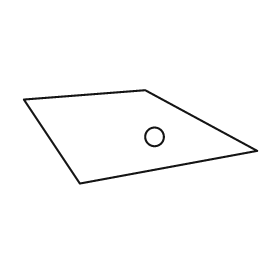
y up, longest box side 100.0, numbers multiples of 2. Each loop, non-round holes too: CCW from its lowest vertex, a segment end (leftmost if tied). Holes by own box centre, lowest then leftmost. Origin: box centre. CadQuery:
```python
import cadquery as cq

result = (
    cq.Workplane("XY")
    .moveTo(-26.0, -20.0)
    .lineTo(50.0, -6.0)
    .lineTo(2.0, 20.0)
    .lineTo(-50.0, 16.0)
    .close()
    .moveTo(6.0, 0.0)
    .circle(4.0)
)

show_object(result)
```